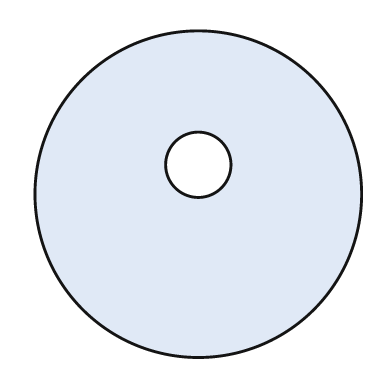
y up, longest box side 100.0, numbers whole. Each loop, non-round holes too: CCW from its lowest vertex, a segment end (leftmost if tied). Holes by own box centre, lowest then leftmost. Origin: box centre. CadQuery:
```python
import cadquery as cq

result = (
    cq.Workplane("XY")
    .moveTo(0.0, 0.0)
    .circle(50.0)
    .moveTo(0.0, 9.0)
    .circle(10.0)
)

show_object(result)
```